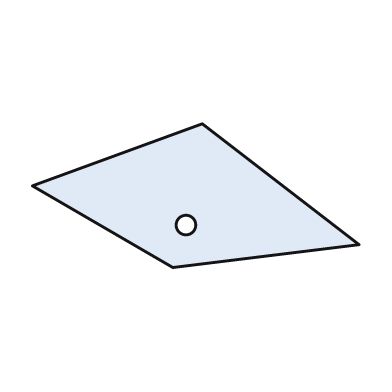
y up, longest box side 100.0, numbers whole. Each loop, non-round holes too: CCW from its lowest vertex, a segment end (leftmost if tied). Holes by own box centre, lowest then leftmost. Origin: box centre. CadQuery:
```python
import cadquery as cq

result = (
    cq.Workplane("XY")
    .moveTo(-7.0, -22.0)
    .lineTo(50.0, -15.0)
    .lineTo(2.0, 22.0)
    .lineTo(-50.0, 3.0)
    .close()
    .moveTo(-3.0, -9.0)
    .circle(3.0)
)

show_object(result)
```